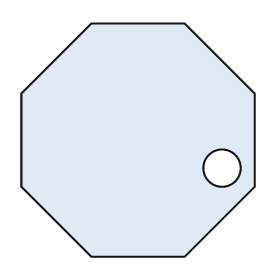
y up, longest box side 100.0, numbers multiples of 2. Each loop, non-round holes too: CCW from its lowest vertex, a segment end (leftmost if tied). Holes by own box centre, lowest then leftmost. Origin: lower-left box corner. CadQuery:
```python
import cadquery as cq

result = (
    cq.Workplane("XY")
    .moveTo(30.0, 0.0)
    .lineTo(70.0, 0.0)
    .lineTo(100.0, 30.0)
    .lineTo(100.0, 70.0)
    .lineTo(70.0, 100.0)
    .lineTo(30.0, 100.0)
    .lineTo(0.0, 70.0)
    .lineTo(0.0, 30.0)
    .close()
    .moveTo(86.0, 38.0)
    .circle(8.0)
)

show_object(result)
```